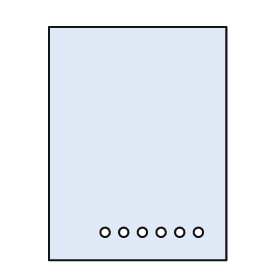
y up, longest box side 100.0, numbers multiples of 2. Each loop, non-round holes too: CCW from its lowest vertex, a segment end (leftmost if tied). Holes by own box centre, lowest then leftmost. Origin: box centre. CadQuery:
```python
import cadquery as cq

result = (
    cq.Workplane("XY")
    .moveTo(-38.0, -50.0)
    .lineTo(38.0, -50.0)
    .lineTo(38.0, 50.0)
    .lineTo(-38.0, 50.0)
    .close()
    .moveTo(-14.0, -38.0)
    .circle(2.0)
    .moveTo(-6.0, -38.0)
    .circle(2.0)
    .moveTo(2.0, -38.0)
    .circle(2.0)
    .moveTo(10.0, -38.0)
    .circle(2.0)
    .moveTo(18.0, -38.0)
    .circle(2.0)
    .moveTo(26.0, -38.0)
    .circle(2.0)
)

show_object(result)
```